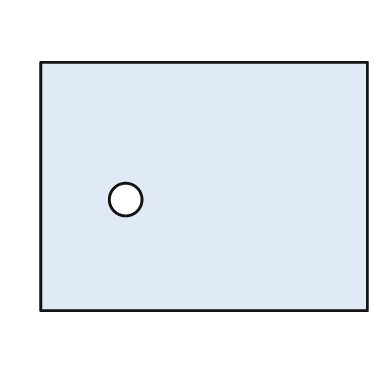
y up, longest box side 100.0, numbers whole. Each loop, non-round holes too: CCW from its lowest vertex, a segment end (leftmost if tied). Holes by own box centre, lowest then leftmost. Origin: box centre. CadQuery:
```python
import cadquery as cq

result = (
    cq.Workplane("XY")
    .moveTo(-50.0, -38.0)
    .lineTo(50.0, -38.0)
    .lineTo(50.0, 38.0)
    .lineTo(-50.0, 38.0)
    .close()
    .moveTo(-24.0, -4.0)
    .circle(5.0)
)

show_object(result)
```